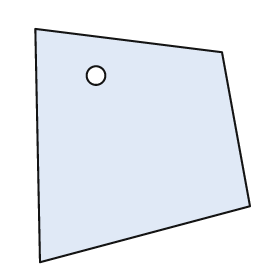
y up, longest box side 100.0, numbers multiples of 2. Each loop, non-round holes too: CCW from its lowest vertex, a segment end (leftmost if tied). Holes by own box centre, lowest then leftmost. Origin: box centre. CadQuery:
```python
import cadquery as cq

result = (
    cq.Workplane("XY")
    .moveTo(-44.0, -50.0)
    .lineTo(46.0, -26.0)
    .lineTo(34.0, 40.0)
    .lineTo(-46.0, 50.0)
    .close()
    .moveTo(-20.0, 30.0)
    .circle(4.0)
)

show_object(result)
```